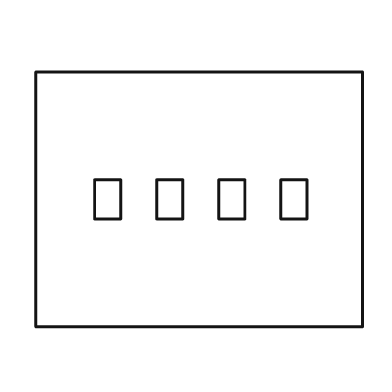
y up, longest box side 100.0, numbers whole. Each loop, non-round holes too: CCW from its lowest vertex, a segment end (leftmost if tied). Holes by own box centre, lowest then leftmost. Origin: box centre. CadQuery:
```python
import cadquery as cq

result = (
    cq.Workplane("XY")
    .moveTo(-50.0, -39.0)
    .lineTo(50.0, -39.0)
    .lineTo(50.0, 39.0)
    .lineTo(-50.0, 39.0)
    .close()
    .moveTo(-32.0, -6.0)
    .lineTo(-24.0, -6.0)
    .lineTo(-24.0, 6.0)
    .lineTo(-32.0, 6.0)
    .close()
    .moveTo(-13.0, -6.0)
    .lineTo(-5.0, -6.0)
    .lineTo(-5.0, 6.0)
    .lineTo(-13.0, 6.0)
    .close()
    .moveTo(6.0, -6.0)
    .lineTo(14.0, -6.0)
    .lineTo(14.0, 6.0)
    .lineTo(6.0, 6.0)
    .close()
    .moveTo(25.0, -6.0)
    .lineTo(33.0, -6.0)
    .lineTo(33.0, 6.0)
    .lineTo(25.0, 6.0)
    .close()
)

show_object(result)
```